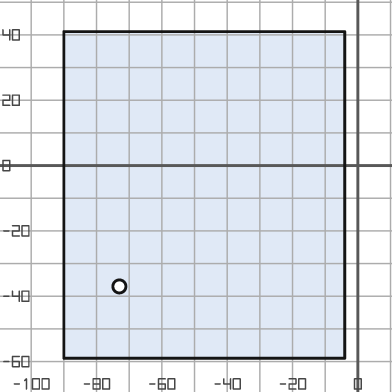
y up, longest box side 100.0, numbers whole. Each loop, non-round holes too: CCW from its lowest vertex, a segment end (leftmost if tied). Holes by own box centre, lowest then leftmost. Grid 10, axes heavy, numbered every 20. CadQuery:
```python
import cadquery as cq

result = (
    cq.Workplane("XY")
    .moveTo(-90.0, -59.0)
    .lineTo(-4.0, -59.0)
    .lineTo(-4.0, 41.0)
    .lineTo(-90.0, 41.0)
    .close()
    .moveTo(-73.0, -37.0)
    .circle(2.0)
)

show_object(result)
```